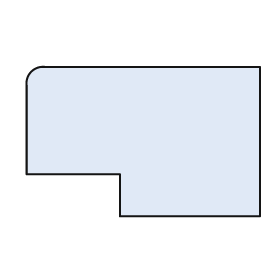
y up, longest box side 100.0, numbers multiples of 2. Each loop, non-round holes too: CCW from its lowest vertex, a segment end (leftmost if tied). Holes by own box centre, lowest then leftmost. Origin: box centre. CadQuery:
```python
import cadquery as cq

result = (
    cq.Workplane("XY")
    .moveTo(-10.0, -32.0)
    .lineTo(50.0, -32.0)
    .lineTo(50.0, 32.0)
    .lineTo(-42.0, 32.0)
    .threePointArc((-48.0, 30.0), (-50.0, 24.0))
    .lineTo(-50.0, -14.0)
    .lineTo(-10.0, -14.0)
    .close()
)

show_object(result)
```